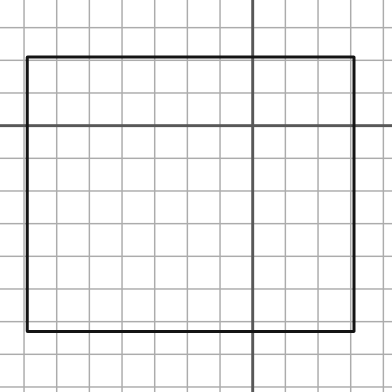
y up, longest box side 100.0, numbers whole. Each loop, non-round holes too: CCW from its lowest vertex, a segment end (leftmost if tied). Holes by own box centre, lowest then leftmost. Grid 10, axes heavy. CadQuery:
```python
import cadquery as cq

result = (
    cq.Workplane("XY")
    .moveTo(-69.0, -63.0)
    .lineTo(31.0, -63.0)
    .lineTo(31.0, 21.0)
    .lineTo(-69.0, 21.0)
    .close()
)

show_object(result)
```